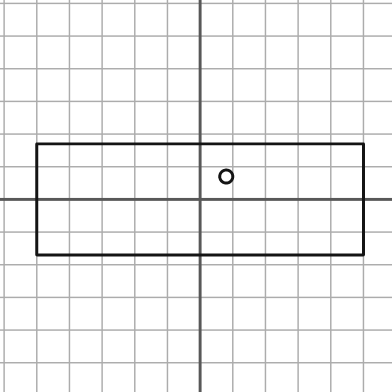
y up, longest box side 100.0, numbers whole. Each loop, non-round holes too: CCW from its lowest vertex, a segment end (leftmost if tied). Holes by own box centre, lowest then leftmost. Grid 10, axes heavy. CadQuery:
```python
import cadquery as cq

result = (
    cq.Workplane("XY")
    .moveTo(-50.0, -17.0)
    .lineTo(50.0, -17.0)
    .lineTo(50.0, 17.0)
    .lineTo(-50.0, 17.0)
    .close()
    .moveTo(8.0, 7.0)
    .circle(2.0)
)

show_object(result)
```